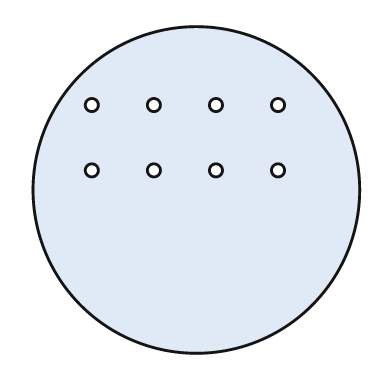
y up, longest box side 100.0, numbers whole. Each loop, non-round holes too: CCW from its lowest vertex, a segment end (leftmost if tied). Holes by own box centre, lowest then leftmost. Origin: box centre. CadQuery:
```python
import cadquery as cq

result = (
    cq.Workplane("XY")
    .moveTo(0.0, 0.0)
    .circle(50.0)
    .moveTo(-32.0, 6.0)
    .circle(2.0)
    .moveTo(-13.0, 6.0)
    .circle(2.0)
    .moveTo(6.0, 6.0)
    .circle(2.0)
    .moveTo(25.0, 6.0)
    .circle(2.0)
    .moveTo(-32.0, 26.0)
    .circle(2.0)
    .moveTo(-13.0, 26.0)
    .circle(2.0)
    .moveTo(6.0, 26.0)
    .circle(2.0)
    .moveTo(25.0, 26.0)
    .circle(2.0)
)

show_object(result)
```